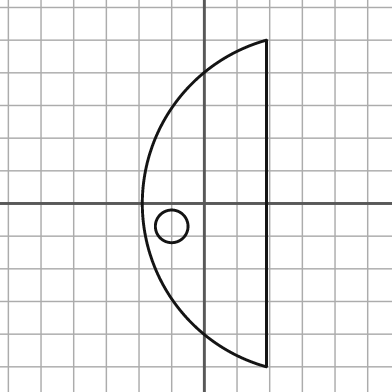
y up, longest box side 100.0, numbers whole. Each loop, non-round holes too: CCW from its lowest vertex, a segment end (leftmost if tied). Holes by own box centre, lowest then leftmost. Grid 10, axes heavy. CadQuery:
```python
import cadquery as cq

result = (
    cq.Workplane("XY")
    .moveTo(19.0, -50.0)
    .lineTo(19.0, 50.0)
    .threePointArc((-19.0, 0.0), (19.0, -50.0))
    .close()
    .moveTo(-10.0, -7.0)
    .circle(5.0)
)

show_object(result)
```